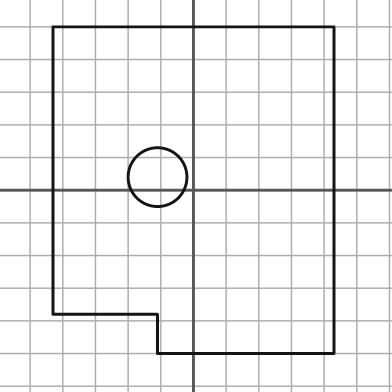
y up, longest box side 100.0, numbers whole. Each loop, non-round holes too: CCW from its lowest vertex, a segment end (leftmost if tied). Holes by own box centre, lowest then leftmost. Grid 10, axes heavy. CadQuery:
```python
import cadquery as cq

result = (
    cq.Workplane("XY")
    .moveTo(-11.0, -50.0)
    .lineTo(43.0, -50.0)
    .lineTo(43.0, 50.0)
    .lineTo(-43.0, 50.0)
    .lineTo(-43.0, -38.0)
    .lineTo(-11.0, -38.0)
    .close()
    .moveTo(-11.0, 4.0)
    .circle(9.0)
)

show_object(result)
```